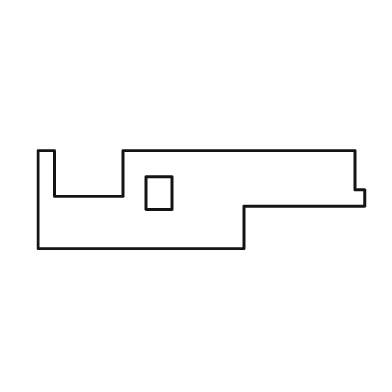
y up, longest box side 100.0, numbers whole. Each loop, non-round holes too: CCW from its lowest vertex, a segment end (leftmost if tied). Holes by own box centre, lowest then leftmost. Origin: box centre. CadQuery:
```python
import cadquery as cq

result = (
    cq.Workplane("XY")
    .moveTo(-50.0, -15.0)
    .lineTo(13.0, -15.0)
    .lineTo(13.0, -2.0)
    .lineTo(50.0, -2.0)
    .lineTo(50.0, 3.0)
    .lineTo(47.0, 3.0)
    .lineTo(47.0, 15.0)
    .lineTo(-24.0, 15.0)
    .lineTo(-24.0, 1.0)
    .lineTo(-45.0, 1.0)
    .lineTo(-45.0, 15.0)
    .lineTo(-50.0, 15.0)
    .close()
    .moveTo(-17.0, -3.0)
    .lineTo(-9.0, -3.0)
    .lineTo(-9.0, 7.0)
    .lineTo(-17.0, 7.0)
    .close()
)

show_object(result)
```